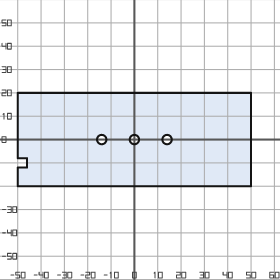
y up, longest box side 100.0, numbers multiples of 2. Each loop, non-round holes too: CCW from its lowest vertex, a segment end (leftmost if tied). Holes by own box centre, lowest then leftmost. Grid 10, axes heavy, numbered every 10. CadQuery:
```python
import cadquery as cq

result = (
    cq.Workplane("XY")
    .moveTo(-50.0, -20.0)
    .lineTo(50.0, -20.0)
    .lineTo(50.0, 20.0)
    .lineTo(-50.0, 20.0)
    .lineTo(-50.0, -8.0)
    .lineTo(-46.0, -8.0)
    .lineTo(-46.0, -12.0)
    .lineTo(-50.0, -12.0)
    .close()
    .moveTo(-14.0, 0.0)
    .circle(2.0)
    .moveTo(0.0, 0.0)
    .circle(2.0)
    .moveTo(14.0, 0.0)
    .circle(2.0)
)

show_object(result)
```